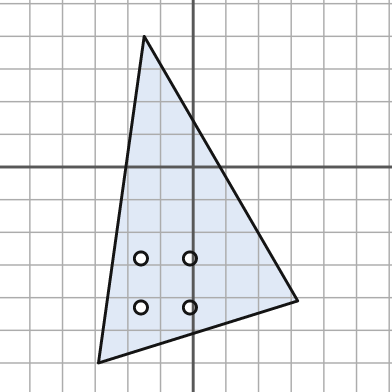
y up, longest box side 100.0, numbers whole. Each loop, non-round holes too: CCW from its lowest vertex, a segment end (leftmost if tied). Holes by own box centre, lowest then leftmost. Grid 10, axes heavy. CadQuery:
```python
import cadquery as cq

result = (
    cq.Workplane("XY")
    .moveTo(-29.0, -60.0)
    .lineTo(32.0, -41.0)
    .lineTo(-15.0, 40.0)
    .close()
    .moveTo(-16.0, -43.0)
    .circle(2.0)
    .moveTo(-1.0, -43.0)
    .circle(2.0)
    .moveTo(-16.0, -28.0)
    .circle(2.0)
    .moveTo(-1.0, -28.0)
    .circle(2.0)
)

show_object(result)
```